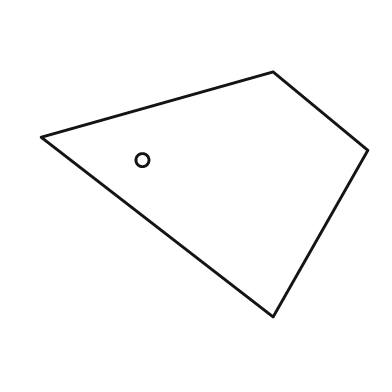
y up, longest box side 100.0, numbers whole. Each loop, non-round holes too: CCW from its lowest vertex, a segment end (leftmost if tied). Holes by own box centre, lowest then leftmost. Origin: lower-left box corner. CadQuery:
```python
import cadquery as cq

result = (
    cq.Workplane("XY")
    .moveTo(71.0, 0.0)
    .lineTo(100.0, 51.0)
    .lineTo(71.0, 75.0)
    .lineTo(0.0, 55.0)
    .close()
    .moveTo(31.0, 48.0)
    .circle(2.0)
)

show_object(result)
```